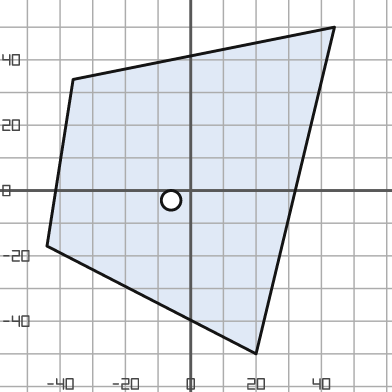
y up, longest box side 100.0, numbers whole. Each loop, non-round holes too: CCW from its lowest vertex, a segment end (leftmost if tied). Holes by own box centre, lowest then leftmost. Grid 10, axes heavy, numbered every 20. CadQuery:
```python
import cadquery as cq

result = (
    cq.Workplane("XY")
    .moveTo(20.0, -50.0)
    .lineTo(44.0, 50.0)
    .lineTo(-36.0, 34.0)
    .lineTo(-44.0, -17.0)
    .close()
    .moveTo(-6.0, -3.0)
    .circle(3.0)
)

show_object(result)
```